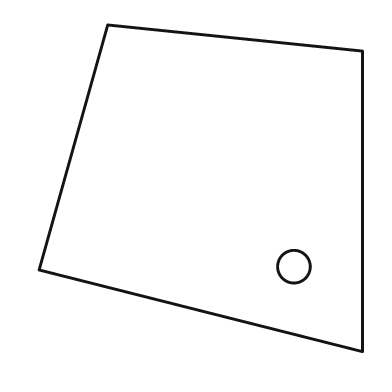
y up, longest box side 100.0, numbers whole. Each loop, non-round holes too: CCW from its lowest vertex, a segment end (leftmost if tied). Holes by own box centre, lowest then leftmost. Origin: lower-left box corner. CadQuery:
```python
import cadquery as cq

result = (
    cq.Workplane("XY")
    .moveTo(99.0, 0.0)
    .lineTo(99.0, 92.0)
    .lineTo(21.0, 100.0)
    .lineTo(0.0, 25.0)
    .close()
    .moveTo(78.0, 26.0)
    .circle(5.0)
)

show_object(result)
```